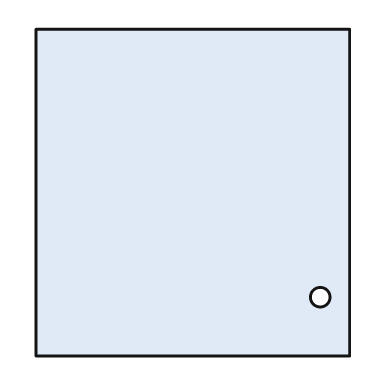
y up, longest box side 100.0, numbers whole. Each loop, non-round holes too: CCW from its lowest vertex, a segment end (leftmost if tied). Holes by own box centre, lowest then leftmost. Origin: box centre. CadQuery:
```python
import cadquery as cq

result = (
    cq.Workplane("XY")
    .moveTo(-48.0, -50.0)
    .lineTo(48.0, -50.0)
    .lineTo(48.0, 50.0)
    .lineTo(-48.0, 50.0)
    .close()
    .moveTo(39.0, -32.0)
    .circle(3.0)
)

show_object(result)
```